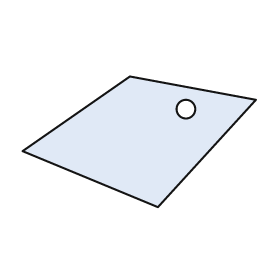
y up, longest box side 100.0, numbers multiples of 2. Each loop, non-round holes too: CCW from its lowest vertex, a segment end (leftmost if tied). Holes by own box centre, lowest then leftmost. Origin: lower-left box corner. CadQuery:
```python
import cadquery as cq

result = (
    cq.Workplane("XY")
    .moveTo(58.0, 0.0)
    .lineTo(100.0, 46.0)
    .lineTo(46.0, 56.0)
    .lineTo(0.0, 24.0)
    .close()
    .moveTo(70.0, 42.0)
    .circle(4.0)
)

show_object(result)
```